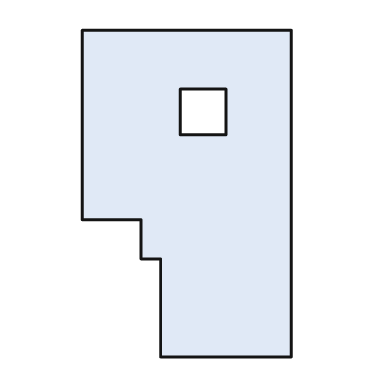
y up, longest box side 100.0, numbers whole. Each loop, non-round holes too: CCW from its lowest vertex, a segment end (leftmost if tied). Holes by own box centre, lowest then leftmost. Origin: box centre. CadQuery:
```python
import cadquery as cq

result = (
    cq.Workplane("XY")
    .moveTo(-8.0, -50.0)
    .lineTo(32.0, -50.0)
    .lineTo(32.0, 50.0)
    .lineTo(-32.0, 50.0)
    .lineTo(-32.0, -8.0)
    .lineTo(-14.0, -8.0)
    .lineTo(-14.0, -20.0)
    .lineTo(-8.0, -20.0)
    .close()
    .moveTo(-2.0, 18.0)
    .lineTo(12.0, 18.0)
    .lineTo(12.0, 32.0)
    .lineTo(-2.0, 32.0)
    .close()
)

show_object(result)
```